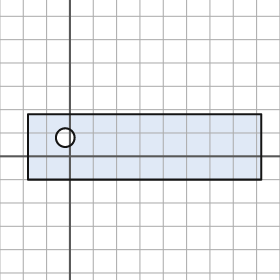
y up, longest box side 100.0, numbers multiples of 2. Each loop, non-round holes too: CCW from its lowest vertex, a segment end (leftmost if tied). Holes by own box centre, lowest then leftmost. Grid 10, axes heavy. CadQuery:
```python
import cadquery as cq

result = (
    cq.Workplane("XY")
    .moveTo(-18.0, -10.0)
    .lineTo(82.0, -10.0)
    .lineTo(82.0, 18.0)
    .lineTo(-18.0, 18.0)
    .close()
    .moveTo(-2.0, 8.0)
    .circle(4.0)
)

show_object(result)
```